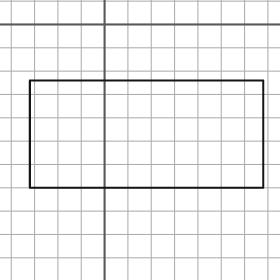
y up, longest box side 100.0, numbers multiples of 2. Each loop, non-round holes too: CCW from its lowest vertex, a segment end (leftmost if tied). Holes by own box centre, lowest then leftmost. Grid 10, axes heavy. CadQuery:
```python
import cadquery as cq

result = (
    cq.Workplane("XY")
    .moveTo(-32.0, -70.0)
    .lineTo(68.0, -70.0)
    .lineTo(68.0, -24.0)
    .lineTo(-32.0, -24.0)
    .close()
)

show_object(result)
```